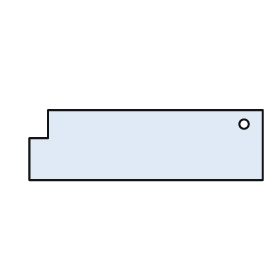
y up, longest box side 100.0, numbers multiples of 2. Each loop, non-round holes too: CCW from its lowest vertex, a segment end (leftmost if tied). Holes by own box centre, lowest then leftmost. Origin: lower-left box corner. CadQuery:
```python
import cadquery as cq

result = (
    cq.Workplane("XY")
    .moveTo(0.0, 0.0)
    .lineTo(100.0, 0.0)
    .lineTo(100.0, 30.0)
    .lineTo(8.0, 30.0)
    .lineTo(8.0, 18.0)
    .lineTo(0.0, 18.0)
    .close()
    .moveTo(92.0, 24.0)
    .circle(2.0)
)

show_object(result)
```